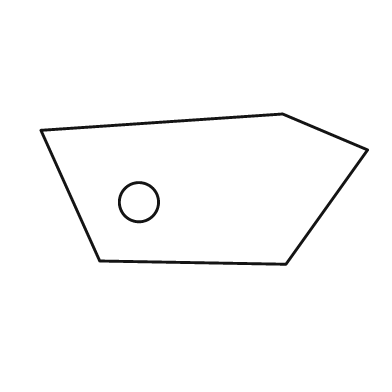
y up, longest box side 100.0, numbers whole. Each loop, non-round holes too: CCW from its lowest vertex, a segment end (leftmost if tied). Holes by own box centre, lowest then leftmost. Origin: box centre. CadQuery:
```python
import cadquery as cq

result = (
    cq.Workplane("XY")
    .moveTo(25.0, -23.0)
    .lineTo(50.0, 12.0)
    .lineTo(24.0, 23.0)
    .lineTo(-50.0, 18.0)
    .lineTo(-32.0, -22.0)
    .close()
    .moveTo(-20.0, -4.0)
    .circle(6.0)
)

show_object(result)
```